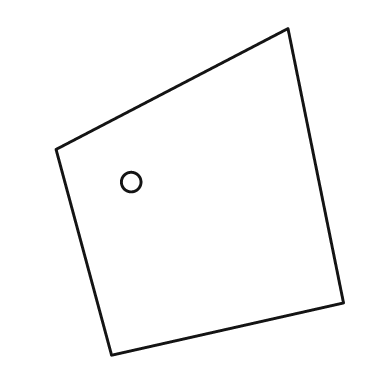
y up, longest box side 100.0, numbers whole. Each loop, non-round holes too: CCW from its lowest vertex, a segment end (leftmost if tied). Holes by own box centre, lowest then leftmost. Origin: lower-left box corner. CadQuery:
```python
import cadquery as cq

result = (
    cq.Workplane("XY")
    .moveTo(17.0, 0.0)
    .lineTo(88.0, 16.0)
    .lineTo(71.0, 100.0)
    .lineTo(0.0, 63.0)
    .close()
    .moveTo(23.0, 53.0)
    .circle(3.0)
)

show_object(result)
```